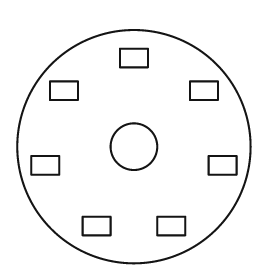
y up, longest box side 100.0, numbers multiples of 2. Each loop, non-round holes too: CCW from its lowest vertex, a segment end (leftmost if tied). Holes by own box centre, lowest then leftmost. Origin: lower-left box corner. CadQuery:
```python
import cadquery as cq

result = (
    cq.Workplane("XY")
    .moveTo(50.0, 50.0)
    .circle(50.0)
    .moveTo(28.0, 12.0)
    .lineTo(40.0, 12.0)
    .lineTo(40.0, 20.0)
    .lineTo(28.0, 20.0)
    .close()
    .moveTo(60.0, 12.0)
    .lineTo(72.0, 12.0)
    .lineTo(72.0, 20.0)
    .lineTo(60.0, 20.0)
    .close()
    .moveTo(6.0, 38.0)
    .lineTo(18.0, 38.0)
    .lineTo(18.0, 46.0)
    .lineTo(6.0, 46.0)
    .close()
    .moveTo(82.0, 38.0)
    .lineTo(94.0, 38.0)
    .lineTo(94.0, 46.0)
    .lineTo(82.0, 46.0)
    .close()
    .moveTo(50.0, 50.0)
    .circle(10.0)
    .moveTo(14.0, 70.0)
    .lineTo(26.0, 70.0)
    .lineTo(26.0, 78.0)
    .lineTo(14.0, 78.0)
    .close()
    .moveTo(74.0, 70.0)
    .lineTo(86.0, 70.0)
    .lineTo(86.0, 78.0)
    .lineTo(74.0, 78.0)
    .close()
    .moveTo(44.0, 84.0)
    .lineTo(56.0, 84.0)
    .lineTo(56.0, 92.0)
    .lineTo(44.0, 92.0)
    .close()
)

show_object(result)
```